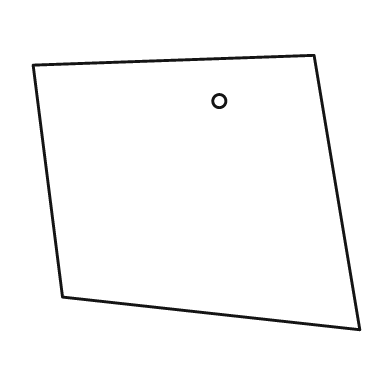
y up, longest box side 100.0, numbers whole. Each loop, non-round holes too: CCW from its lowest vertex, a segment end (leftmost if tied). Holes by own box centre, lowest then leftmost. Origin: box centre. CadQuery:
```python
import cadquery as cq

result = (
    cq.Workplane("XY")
    .moveTo(50.0, -42.0)
    .lineTo(36.0, 42.0)
    .lineTo(-50.0, 39.0)
    .lineTo(-41.0, -32.0)
    .close()
    .moveTo(7.0, 28.0)
    .circle(2.0)
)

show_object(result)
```